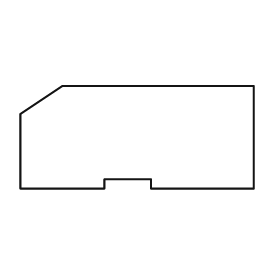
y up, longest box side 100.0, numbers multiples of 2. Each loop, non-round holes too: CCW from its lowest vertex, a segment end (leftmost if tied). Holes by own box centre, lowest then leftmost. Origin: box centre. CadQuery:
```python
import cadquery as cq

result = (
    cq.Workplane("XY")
    .moveTo(-50.0, -22.0)
    .lineTo(-14.0, -22.0)
    .lineTo(-14.0, -18.0)
    .lineTo(6.0, -18.0)
    .lineTo(6.0, -22.0)
    .lineTo(50.0, -22.0)
    .lineTo(50.0, 22.0)
    .lineTo(-32.0, 22.0)
    .lineTo(-50.0, 10.0)
    .close()
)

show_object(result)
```